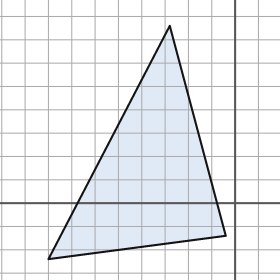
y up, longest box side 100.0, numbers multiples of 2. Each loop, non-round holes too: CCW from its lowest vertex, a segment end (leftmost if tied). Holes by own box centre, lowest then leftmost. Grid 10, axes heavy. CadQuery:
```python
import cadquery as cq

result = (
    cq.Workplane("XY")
    .moveTo(-80.0, -24.0)
    .lineTo(-4.0, -14.0)
    .lineTo(-28.0, 76.0)
    .close()
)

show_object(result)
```